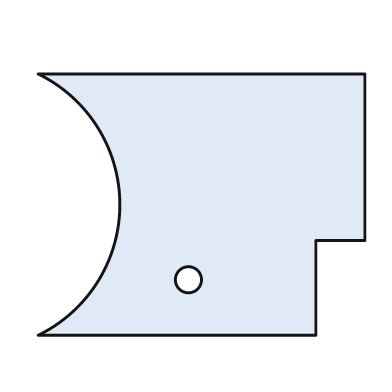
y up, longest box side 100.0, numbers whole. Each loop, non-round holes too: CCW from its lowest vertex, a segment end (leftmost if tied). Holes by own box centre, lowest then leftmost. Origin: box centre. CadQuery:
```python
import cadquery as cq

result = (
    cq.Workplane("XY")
    .moveTo(-50.0, -40.0)
    .lineTo(35.0, -40.0)
    .lineTo(35.0, -11.0)
    .lineTo(50.0, -11.0)
    .lineTo(50.0, 40.0)
    .lineTo(-50.0, 40.0)
    .threePointArc((-25.0, 0.0), (-50.0, -40.0))
    .close()
    .moveTo(-4.0, -23.0)
    .circle(4.0)
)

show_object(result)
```